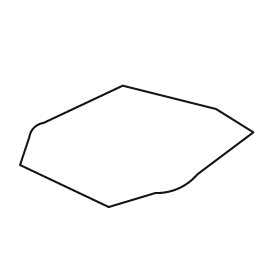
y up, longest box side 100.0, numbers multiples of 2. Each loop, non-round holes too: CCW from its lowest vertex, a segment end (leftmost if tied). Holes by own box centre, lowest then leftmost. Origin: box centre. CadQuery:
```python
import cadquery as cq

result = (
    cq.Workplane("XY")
    .moveTo(-12.0, -26.0)
    .lineTo(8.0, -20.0)
    .threePointArc((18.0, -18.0), (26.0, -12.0))
    .lineTo(50.0, 6.0)
    .lineTo(34.0, 16.0)
    .lineTo(-6.0, 26.0)
    .lineTo(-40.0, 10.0)
    .threePointArc((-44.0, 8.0), (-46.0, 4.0))
    .lineTo(-50.0, -8.0)
    .close()
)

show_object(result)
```